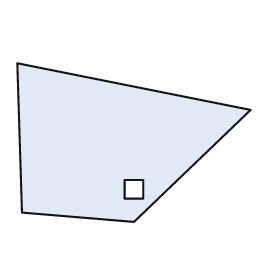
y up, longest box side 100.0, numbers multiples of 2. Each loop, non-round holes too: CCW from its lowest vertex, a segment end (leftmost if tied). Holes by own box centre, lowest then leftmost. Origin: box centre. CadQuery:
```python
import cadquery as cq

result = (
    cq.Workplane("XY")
    .moveTo(0.0, -34.0)
    .lineTo(50.0, 14.0)
    .lineTo(-50.0, 34.0)
    .lineTo(-48.0, -30.0)
    .close()
    .moveTo(-4.0, -24.0)
    .lineTo(4.0, -24.0)
    .lineTo(4.0, -16.0)
    .lineTo(-4.0, -16.0)
    .close()
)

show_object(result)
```